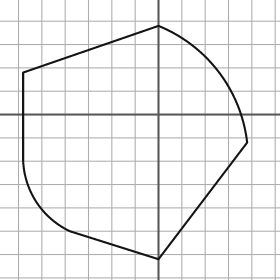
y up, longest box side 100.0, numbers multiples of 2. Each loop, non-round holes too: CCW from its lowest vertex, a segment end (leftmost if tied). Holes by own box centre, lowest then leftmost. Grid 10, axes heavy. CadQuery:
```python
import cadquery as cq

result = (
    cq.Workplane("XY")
    .moveTo(0.0, -62.0)
    .lineTo(38.0, -12.0)
    .threePointArc((26.0, 18.0), (0.0, 38.0))
    .lineTo(-58.0, 18.0)
    .lineTo(-58.0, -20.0)
    .threePointArc((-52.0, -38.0), (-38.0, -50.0))
    .close()
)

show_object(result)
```